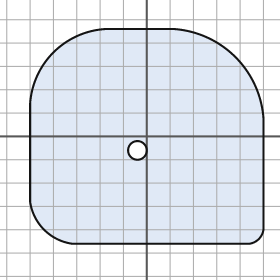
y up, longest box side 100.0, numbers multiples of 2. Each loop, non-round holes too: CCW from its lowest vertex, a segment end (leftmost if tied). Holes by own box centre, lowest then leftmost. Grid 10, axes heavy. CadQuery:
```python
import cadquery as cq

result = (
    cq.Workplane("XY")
    .moveTo(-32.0, -46.0)
    .lineTo(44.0, -46.0)
    .threePointArc((48.0, -44.0), (50.0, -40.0))
    .lineTo(50.0, 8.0)
    .threePointArc((38.0, 34.0), (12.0, 46.0))
    .lineTo(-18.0, 46.0)
    .threePointArc((-40.0, 36.0), (-50.0, 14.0))
    .lineTo(-50.0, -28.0)
    .threePointArc((-44.0, -40.0), (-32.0, -46.0))
    .close()
    .moveTo(-4.0, -6.0)
    .circle(4.0)
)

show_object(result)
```